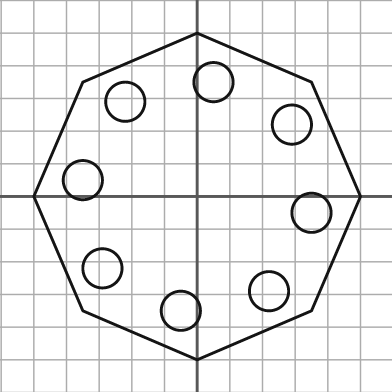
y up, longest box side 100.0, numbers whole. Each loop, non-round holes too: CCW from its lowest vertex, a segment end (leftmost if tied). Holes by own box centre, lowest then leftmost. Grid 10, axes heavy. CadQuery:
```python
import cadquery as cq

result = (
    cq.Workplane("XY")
    .moveTo(0.0, -50.0)
    .lineTo(35.0, -35.0)
    .lineTo(50.0, 0.0)
    .lineTo(35.0, 35.0)
    .lineTo(0.0, 50.0)
    .lineTo(-35.0, 35.0)
    .lineTo(-50.0, 0.0)
    .lineTo(-35.0, -35.0)
    .close()
    .moveTo(-5.0, -35.0)
    .circle(6.0)
    .moveTo(22.0, -29.0)
    .circle(6.0)
    .moveTo(-29.0, -22.0)
    .circle(6.0)
    .moveTo(35.0, -5.0)
    .circle(6.0)
    .moveTo(-35.0, 5.0)
    .circle(6.0)
    .moveTo(29.0, 22.0)
    .circle(6.0)
    .moveTo(-22.0, 29.0)
    .circle(6.0)
    .moveTo(5.0, 35.0)
    .circle(6.0)
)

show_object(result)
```